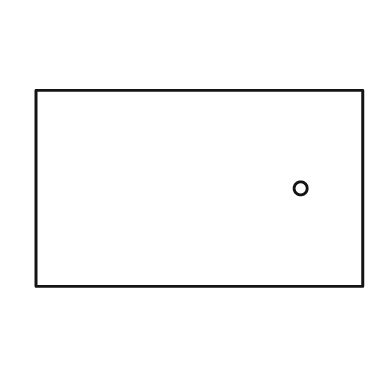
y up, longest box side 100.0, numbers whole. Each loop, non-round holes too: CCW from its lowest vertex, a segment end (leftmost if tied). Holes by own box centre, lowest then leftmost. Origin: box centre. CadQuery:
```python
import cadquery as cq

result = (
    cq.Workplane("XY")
    .moveTo(-50.0, -30.0)
    .lineTo(50.0, -30.0)
    .lineTo(50.0, 30.0)
    .lineTo(-50.0, 30.0)
    .close()
    .moveTo(31.0, 0.0)
    .circle(2.0)
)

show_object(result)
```